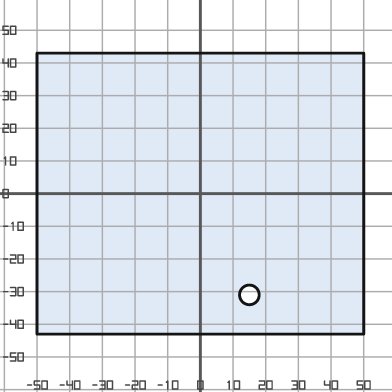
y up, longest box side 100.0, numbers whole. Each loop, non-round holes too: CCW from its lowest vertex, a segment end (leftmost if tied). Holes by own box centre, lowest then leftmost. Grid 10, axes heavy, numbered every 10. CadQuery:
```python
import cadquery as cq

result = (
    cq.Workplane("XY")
    .moveTo(-50.0, -43.0)
    .lineTo(50.0, -43.0)
    .lineTo(50.0, 43.0)
    .lineTo(-50.0, 43.0)
    .close()
    .moveTo(15.0, -31.0)
    .circle(3.0)
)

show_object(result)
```